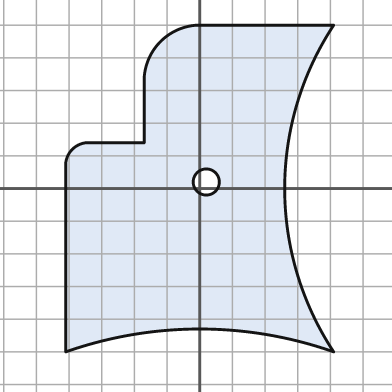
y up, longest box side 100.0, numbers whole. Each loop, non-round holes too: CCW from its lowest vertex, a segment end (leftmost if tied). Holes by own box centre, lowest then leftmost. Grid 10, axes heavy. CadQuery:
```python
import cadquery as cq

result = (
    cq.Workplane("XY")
    .moveTo(-41.0, -50.0)
    .threePointArc((0.0, -43.0), (41.0, -50.0))
    .threePointArc((26.0, 0.0), (41.0, 50.0))
    .lineTo(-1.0, 50.0)
    .threePointArc((-12.0, 45.0), (-17.0, 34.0))
    .lineTo(-17.0, 14.0)
    .lineTo(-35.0, 14.0)
    .threePointArc((-39.0, 12.0), (-41.0, 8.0))
    .close()
    .moveTo(2.0, 2.0)
    .circle(4.0)
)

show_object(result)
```